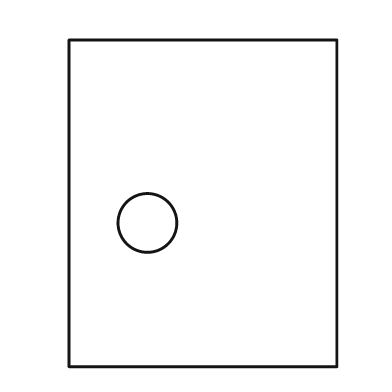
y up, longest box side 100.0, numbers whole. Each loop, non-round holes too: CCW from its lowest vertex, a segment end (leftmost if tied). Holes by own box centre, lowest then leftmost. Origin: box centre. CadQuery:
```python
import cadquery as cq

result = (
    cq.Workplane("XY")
    .moveTo(-41.0, -50.0)
    .lineTo(41.0, -50.0)
    .lineTo(41.0, 50.0)
    .lineTo(-41.0, 50.0)
    .close()
    .moveTo(-17.0, -6.0)
    .circle(9.0)
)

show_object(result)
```